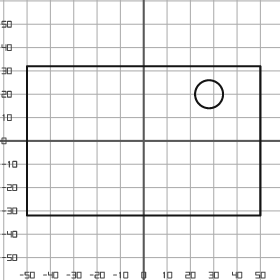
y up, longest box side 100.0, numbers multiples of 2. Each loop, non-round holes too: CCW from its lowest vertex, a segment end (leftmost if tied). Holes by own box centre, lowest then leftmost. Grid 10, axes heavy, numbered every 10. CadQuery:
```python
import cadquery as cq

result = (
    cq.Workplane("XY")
    .moveTo(-50.0, -32.0)
    .lineTo(50.0, -32.0)
    .lineTo(50.0, 32.0)
    .lineTo(-50.0, 32.0)
    .close()
    .moveTo(28.0, 20.0)
    .circle(6.0)
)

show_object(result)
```